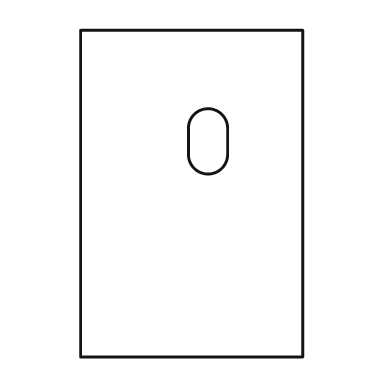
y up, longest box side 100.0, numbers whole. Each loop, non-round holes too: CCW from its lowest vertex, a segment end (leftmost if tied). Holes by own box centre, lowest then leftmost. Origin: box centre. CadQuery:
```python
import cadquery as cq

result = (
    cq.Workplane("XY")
    .moveTo(-34.0, -50.0)
    .lineTo(34.0, -50.0)
    .lineTo(34.0, 50.0)
    .lineTo(-34.0, 50.0)
    .close()
    .moveTo(-1.0, 12.0)
    .threePointArc((5.0, 6.0), (11.0, 12.0))
    .lineTo(11.0, 20.0)
    .threePointArc((5.0, 26.0), (-1.0, 20.0))
    .close()
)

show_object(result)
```